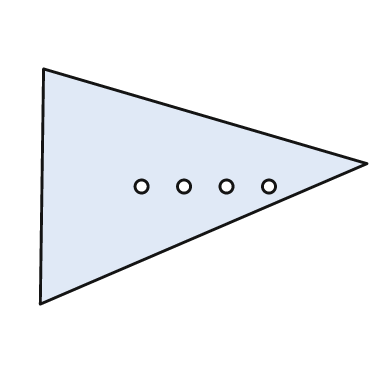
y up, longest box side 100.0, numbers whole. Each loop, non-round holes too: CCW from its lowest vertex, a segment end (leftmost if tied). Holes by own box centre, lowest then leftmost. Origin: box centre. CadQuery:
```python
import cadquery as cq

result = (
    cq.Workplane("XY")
    .moveTo(-50.0, -36.0)
    .lineTo(50.0, 7.0)
    .lineTo(-49.0, 36.0)
    .close()
    .moveTo(-19.0, 0.0)
    .circle(2.0)
    .moveTo(-6.0, 0.0)
    .circle(2.0)
    .moveTo(7.0, 0.0)
    .circle(2.0)
    .moveTo(20.0, 0.0)
    .circle(2.0)
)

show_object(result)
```